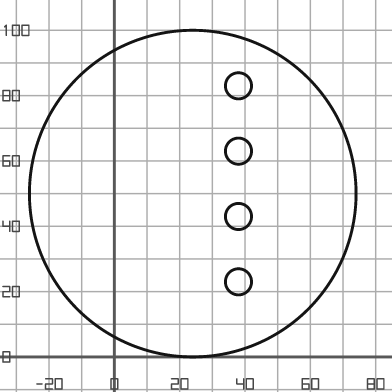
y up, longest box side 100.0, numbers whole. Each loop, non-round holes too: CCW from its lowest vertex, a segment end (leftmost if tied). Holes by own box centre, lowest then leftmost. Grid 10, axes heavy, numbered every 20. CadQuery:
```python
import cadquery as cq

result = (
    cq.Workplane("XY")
    .moveTo(24.0, 50.0)
    .circle(50.0)
    .moveTo(38.0, 23.0)
    .circle(4.0)
    .moveTo(38.0, 43.0)
    .circle(4.0)
    .moveTo(38.0, 63.0)
    .circle(4.0)
    .moveTo(38.0, 83.0)
    .circle(4.0)
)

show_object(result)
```